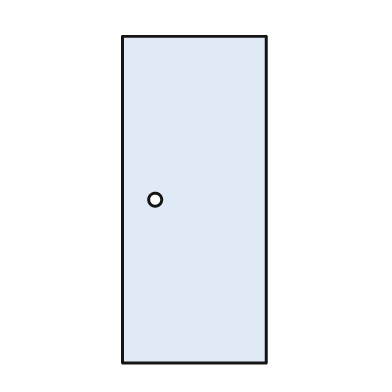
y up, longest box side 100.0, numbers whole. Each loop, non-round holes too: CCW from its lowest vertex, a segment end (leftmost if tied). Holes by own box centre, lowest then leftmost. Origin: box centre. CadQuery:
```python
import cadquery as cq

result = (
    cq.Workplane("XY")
    .moveTo(-22.0, -50.0)
    .lineTo(22.0, -50.0)
    .lineTo(22.0, 50.0)
    .lineTo(-22.0, 50.0)
    .close()
    .moveTo(-12.0, 0.0)
    .circle(2.0)
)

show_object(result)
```